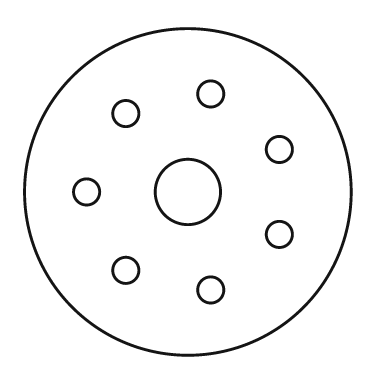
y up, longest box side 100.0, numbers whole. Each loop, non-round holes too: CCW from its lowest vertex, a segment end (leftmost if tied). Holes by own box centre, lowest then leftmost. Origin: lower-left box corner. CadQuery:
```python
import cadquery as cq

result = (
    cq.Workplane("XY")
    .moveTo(50.0, 50.0)
    .circle(50.0)
    .moveTo(57.0, 20.0)
    .circle(4.0)
    .moveTo(31.0, 26.0)
    .circle(4.0)
    .moveTo(78.0, 37.0)
    .circle(4.0)
    .moveTo(19.0, 50.0)
    .circle(4.0)
    .moveTo(50.0, 50.0)
    .circle(10.0)
    .moveTo(78.0, 63.0)
    .circle(4.0)
    .moveTo(31.0, 74.0)
    .circle(4.0)
    .moveTo(57.0, 80.0)
    .circle(4.0)
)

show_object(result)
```